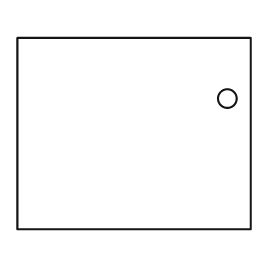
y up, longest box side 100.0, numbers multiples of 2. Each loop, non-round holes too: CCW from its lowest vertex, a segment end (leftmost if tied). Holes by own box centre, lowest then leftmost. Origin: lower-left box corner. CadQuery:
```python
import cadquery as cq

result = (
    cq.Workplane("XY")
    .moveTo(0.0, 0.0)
    .lineTo(100.0, 0.0)
    .lineTo(100.0, 82.0)
    .lineTo(0.0, 82.0)
    .close()
    .moveTo(90.0, 56.0)
    .circle(4.0)
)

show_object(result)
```